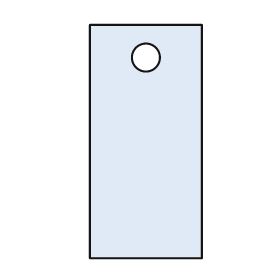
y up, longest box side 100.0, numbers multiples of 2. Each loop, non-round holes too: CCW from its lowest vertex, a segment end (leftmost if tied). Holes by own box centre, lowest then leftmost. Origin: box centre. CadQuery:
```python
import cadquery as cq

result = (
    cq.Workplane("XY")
    .moveTo(-24.0, -50.0)
    .lineTo(24.0, -50.0)
    .lineTo(24.0, 50.0)
    .lineTo(-24.0, 50.0)
    .close()
    .moveTo(0.0, 36.0)
    .circle(6.0)
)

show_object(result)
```